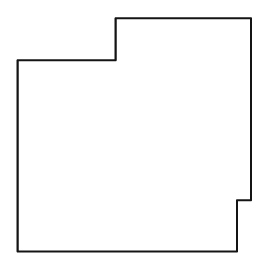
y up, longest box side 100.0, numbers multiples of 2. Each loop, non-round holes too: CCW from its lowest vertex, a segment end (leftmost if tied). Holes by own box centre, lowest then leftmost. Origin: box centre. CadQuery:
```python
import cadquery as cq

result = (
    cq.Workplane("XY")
    .moveTo(-50.0, -50.0)
    .lineTo(44.0, -50.0)
    .lineTo(44.0, -28.0)
    .lineTo(50.0, -28.0)
    .lineTo(50.0, 50.0)
    .lineTo(-8.0, 50.0)
    .lineTo(-8.0, 32.0)
    .lineTo(-50.0, 32.0)
    .close()
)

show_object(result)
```